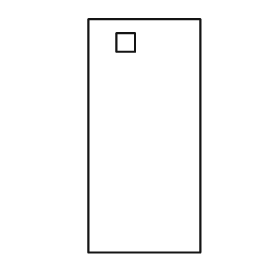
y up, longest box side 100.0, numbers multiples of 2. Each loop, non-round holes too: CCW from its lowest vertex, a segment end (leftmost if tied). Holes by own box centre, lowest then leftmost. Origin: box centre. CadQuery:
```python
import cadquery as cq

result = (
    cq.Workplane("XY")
    .moveTo(-24.0, -50.0)
    .lineTo(24.0, -50.0)
    .lineTo(24.0, 50.0)
    .lineTo(-24.0, 50.0)
    .close()
    .moveTo(-12.0, 36.0)
    .lineTo(-4.0, 36.0)
    .lineTo(-4.0, 44.0)
    .lineTo(-12.0, 44.0)
    .close()
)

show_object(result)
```